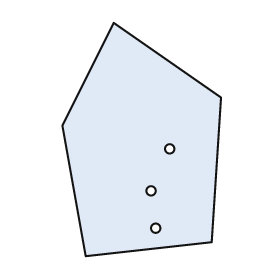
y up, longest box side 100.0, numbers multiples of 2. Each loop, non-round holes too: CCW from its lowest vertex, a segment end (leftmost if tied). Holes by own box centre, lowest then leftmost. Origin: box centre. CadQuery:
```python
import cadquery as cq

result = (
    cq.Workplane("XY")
    .moveTo(-24.0, -50.0)
    .lineTo(30.0, -44.0)
    .lineTo(34.0, 18.0)
    .lineTo(-12.0, 50.0)
    .lineTo(-34.0, 6.0)
    .close()
    .moveTo(6.0, -38.0)
    .circle(2.0)
    .moveTo(4.0, -22.0)
    .circle(2.0)
    .moveTo(12.0, -4.0)
    .circle(2.0)
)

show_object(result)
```